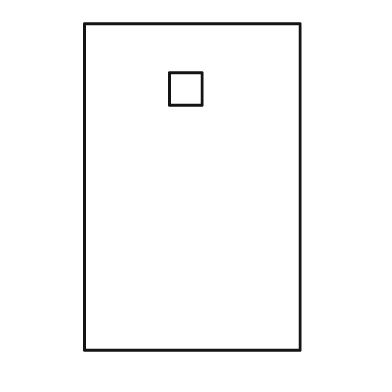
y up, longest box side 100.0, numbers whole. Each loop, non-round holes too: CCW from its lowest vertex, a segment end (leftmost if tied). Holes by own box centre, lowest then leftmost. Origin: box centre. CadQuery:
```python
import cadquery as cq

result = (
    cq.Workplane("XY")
    .moveTo(-33.0, -50.0)
    .lineTo(33.0, -50.0)
    .lineTo(33.0, 50.0)
    .lineTo(-33.0, 50.0)
    .close()
    .moveTo(-7.0, 25.0)
    .lineTo(3.0, 25.0)
    .lineTo(3.0, 35.0)
    .lineTo(-7.0, 35.0)
    .close()
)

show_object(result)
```